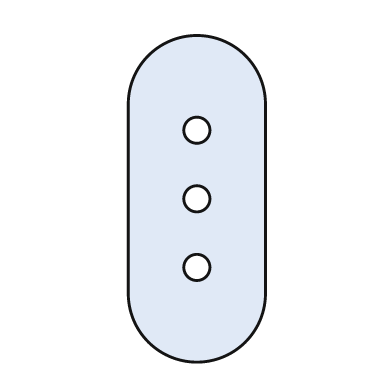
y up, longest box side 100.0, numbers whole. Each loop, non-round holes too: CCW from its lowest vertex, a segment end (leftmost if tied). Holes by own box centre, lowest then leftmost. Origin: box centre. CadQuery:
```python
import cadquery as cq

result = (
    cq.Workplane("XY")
    .moveTo(-21.0, -29.0)
    .threePointArc((0.0, -50.0), (21.0, -29.0))
    .lineTo(21.0, 29.0)
    .threePointArc((0.0, 50.0), (-21.0, 29.0))
    .close()
    .moveTo(0.0, -21.0)
    .circle(4.0)
    .moveTo(0.0, 0.0)
    .circle(4.0)
    .moveTo(0.0, 21.0)
    .circle(4.0)
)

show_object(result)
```